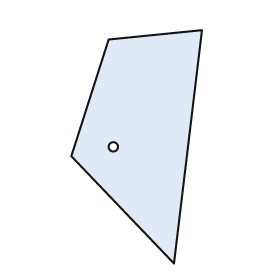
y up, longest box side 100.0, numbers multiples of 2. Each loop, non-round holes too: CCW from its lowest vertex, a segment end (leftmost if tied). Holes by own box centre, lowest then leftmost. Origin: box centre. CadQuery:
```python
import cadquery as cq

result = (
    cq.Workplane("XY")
    .moveTo(16.0, -50.0)
    .lineTo(28.0, 50.0)
    .lineTo(-12.0, 46.0)
    .lineTo(-28.0, -4.0)
    .close()
    .moveTo(-10.0, 0.0)
    .circle(2.0)
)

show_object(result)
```